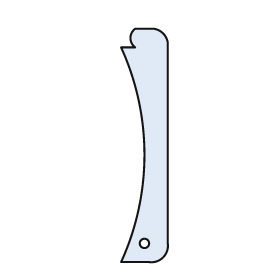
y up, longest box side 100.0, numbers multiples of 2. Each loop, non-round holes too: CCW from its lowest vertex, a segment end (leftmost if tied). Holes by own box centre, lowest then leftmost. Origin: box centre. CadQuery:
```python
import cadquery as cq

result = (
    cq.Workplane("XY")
    .moveTo(-10.0, -50.0)
    .lineTo(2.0, -50.0)
    .threePointArc((8.0, -48.0), (10.0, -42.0))
    .lineTo(10.0, 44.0)
    .threePointArc((8.0, 48.0), (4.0, 50.0))
    .lineTo(-4.0, 50.0)
    .threePointArc((-6.0, 46.0), (-4.0, 42.0))
    .lineTo(-10.0, 42.0)
    .threePointArc((0.0, -4.0), (-10.0, -50.0))
    .close()
    .moveTo(0.0, -42.0)
    .circle(2.0)
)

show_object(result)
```